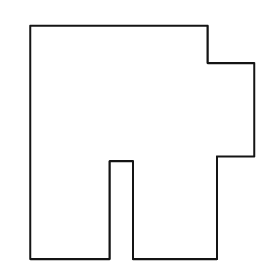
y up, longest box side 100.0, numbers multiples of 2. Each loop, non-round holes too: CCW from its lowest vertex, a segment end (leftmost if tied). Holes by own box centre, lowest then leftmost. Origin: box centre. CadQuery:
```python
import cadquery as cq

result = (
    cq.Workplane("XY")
    .moveTo(-48.0, -50.0)
    .lineTo(-14.0, -50.0)
    .lineTo(-14.0, -8.0)
    .lineTo(-4.0, -8.0)
    .lineTo(-4.0, -50.0)
    .lineTo(32.0, -50.0)
    .lineTo(32.0, -6.0)
    .lineTo(48.0, -6.0)
    .lineTo(48.0, 34.0)
    .lineTo(28.0, 34.0)
    .lineTo(28.0, 50.0)
    .lineTo(-48.0, 50.0)
    .close()
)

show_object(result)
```